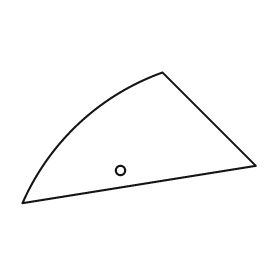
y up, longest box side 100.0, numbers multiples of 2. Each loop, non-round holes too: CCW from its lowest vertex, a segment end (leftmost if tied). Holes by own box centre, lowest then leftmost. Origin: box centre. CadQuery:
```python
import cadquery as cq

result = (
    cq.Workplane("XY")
    .moveTo(-50.0, -28.0)
    .lineTo(50.0, -12.0)
    .lineTo(10.0, 28.0)
    .threePointArc((-26.0, 6.0), (-50.0, -28.0))
    .close()
    .moveTo(-8.0, -14.0)
    .circle(2.0)
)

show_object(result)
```